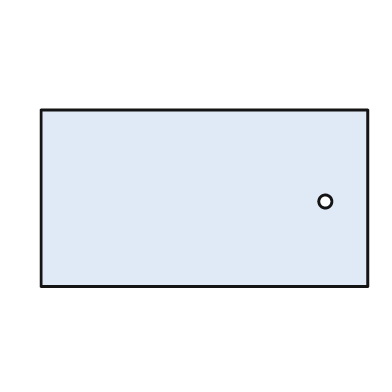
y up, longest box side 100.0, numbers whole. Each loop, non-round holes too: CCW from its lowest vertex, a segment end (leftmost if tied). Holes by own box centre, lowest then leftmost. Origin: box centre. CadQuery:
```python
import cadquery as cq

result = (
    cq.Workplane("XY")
    .moveTo(-50.0, -27.0)
    .lineTo(50.0, -27.0)
    .lineTo(50.0, 27.0)
    .lineTo(-50.0, 27.0)
    .close()
    .moveTo(37.0, -1.0)
    .circle(2.0)
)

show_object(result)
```